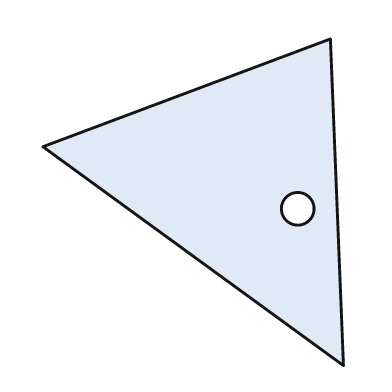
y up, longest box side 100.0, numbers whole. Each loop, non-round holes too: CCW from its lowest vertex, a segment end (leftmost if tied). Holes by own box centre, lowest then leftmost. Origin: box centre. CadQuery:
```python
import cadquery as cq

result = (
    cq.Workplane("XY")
    .moveTo(46.0, -50.0)
    .lineTo(42.0, 50.0)
    .lineTo(-46.0, 17.0)
    .close()
    .moveTo(32.0, -2.0)
    .circle(5.0)
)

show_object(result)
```